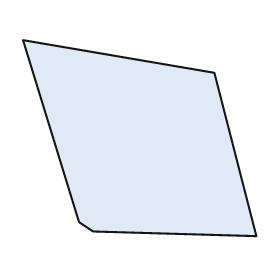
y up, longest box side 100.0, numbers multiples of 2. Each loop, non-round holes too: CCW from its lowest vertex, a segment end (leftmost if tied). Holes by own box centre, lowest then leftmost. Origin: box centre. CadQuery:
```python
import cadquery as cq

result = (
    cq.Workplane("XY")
    .moveTo(50.0, -42.0)
    .lineTo(32.0, 28.0)
    .lineTo(-50.0, 42.0)
    .lineTo(-26.0, -36.0)
    .lineTo(-20.0, -40.0)
    .close()
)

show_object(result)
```